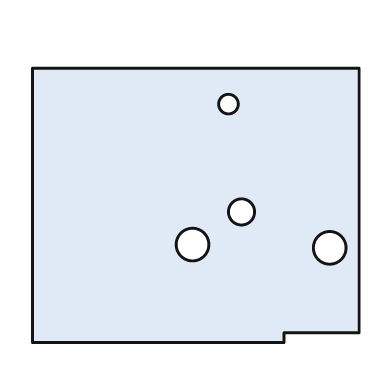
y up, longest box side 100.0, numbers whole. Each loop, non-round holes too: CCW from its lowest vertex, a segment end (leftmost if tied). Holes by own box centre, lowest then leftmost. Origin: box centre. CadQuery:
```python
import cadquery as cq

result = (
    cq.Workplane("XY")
    .moveTo(-50.0, -42.0)
    .lineTo(27.0, -42.0)
    .lineTo(27.0, -39.0)
    .lineTo(50.0, -39.0)
    .lineTo(50.0, 42.0)
    .lineTo(-50.0, 42.0)
    .close()
    .moveTo(41.0, -13.0)
    .circle(5.0)
    .moveTo(-1.0, -12.0)
    .circle(5.0)
    .moveTo(14.0, -2.0)
    .circle(4.0)
    .moveTo(10.0, 31.0)
    .circle(3.0)
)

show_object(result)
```